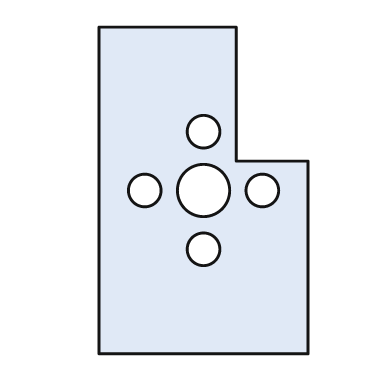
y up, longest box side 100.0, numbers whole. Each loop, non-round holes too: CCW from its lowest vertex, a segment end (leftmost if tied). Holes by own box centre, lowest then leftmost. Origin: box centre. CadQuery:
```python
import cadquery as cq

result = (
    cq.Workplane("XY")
    .moveTo(-32.0, -50.0)
    .lineTo(32.0, -50.0)
    .lineTo(32.0, 9.0)
    .lineTo(10.0, 9.0)
    .lineTo(10.0, 50.0)
    .lineTo(-32.0, 50.0)
    .close()
    .moveTo(0.0, -18.0)
    .circle(5.0)
    .moveTo(-18.0, 0.0)
    .circle(5.0)
    .moveTo(0.0, 0.0)
    .circle(8.0)
    .moveTo(18.0, 0.0)
    .circle(5.0)
    .moveTo(0.0, 18.0)
    .circle(5.0)
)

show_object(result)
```